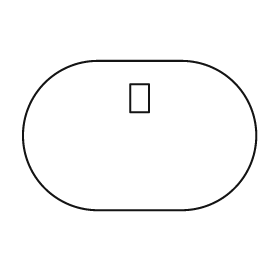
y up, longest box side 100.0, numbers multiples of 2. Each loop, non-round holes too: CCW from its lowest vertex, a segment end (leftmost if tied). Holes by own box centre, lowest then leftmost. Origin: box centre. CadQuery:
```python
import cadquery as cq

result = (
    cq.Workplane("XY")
    .moveTo(-18.0, -32.0)
    .lineTo(18.0, -32.0)
    .threePointArc((50.0, 0.0), (18.0, 32.0))
    .lineTo(-18.0, 32.0)
    .threePointArc((-50.0, 0.0), (-18.0, -32.0))
    .close()
    .moveTo(-4.0, 10.0)
    .lineTo(4.0, 10.0)
    .lineTo(4.0, 22.0)
    .lineTo(-4.0, 22.0)
    .close()
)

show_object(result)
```